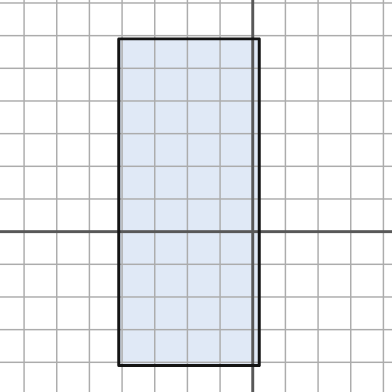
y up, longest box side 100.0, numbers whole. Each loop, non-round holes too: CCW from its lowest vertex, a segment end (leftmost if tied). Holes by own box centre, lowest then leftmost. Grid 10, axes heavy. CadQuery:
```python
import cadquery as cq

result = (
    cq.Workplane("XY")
    .moveTo(-41.0, -41.0)
    .lineTo(2.0, -41.0)
    .lineTo(2.0, 59.0)
    .lineTo(-41.0, 59.0)
    .close()
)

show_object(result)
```